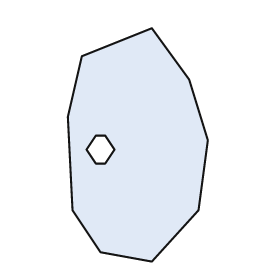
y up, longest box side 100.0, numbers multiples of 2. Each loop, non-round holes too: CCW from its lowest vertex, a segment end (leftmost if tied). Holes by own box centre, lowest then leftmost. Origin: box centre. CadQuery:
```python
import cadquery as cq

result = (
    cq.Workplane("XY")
    .moveTo(6.0, -50.0)
    .lineTo(26.0, -28.0)
    .lineTo(30.0, 2.0)
    .lineTo(22.0, 28.0)
    .lineTo(6.0, 50.0)
    .lineTo(-24.0, 38.0)
    .lineTo(-30.0, 12.0)
    .lineTo(-28.0, -28.0)
    .lineTo(-16.0, -46.0)
    .close()
    .moveTo(-18.0, -8.0)
    .lineTo(-14.0, -8.0)
    .lineTo(-10.0, -2.0)
    .lineTo(-14.0, 4.0)
    .lineTo(-18.0, 4.0)
    .lineTo(-22.0, -2.0)
    .close()
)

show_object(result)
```